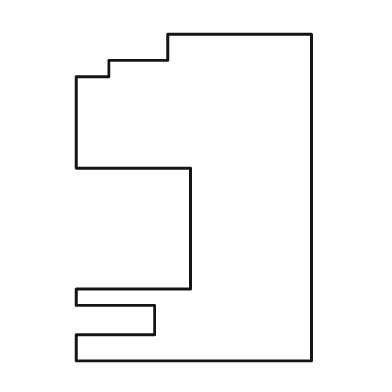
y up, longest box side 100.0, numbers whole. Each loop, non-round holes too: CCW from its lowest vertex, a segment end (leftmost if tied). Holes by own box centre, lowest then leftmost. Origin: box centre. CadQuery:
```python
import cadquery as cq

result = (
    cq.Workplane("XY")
    .moveTo(-36.0, -50.0)
    .lineTo(36.0, -50.0)
    .lineTo(36.0, 50.0)
    .lineTo(-8.0, 50.0)
    .lineTo(-8.0, 42.0)
    .lineTo(-26.0, 42.0)
    .lineTo(-26.0, 37.0)
    .lineTo(-36.0, 37.0)
    .lineTo(-36.0, 9.0)
    .lineTo(-1.0, 9.0)
    .lineTo(-1.0, -28.0)
    .lineTo(-36.0, -28.0)
    .lineTo(-36.0, -33.0)
    .lineTo(-12.0, -33.0)
    .lineTo(-12.0, -42.0)
    .lineTo(-36.0, -42.0)
    .close()
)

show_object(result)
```